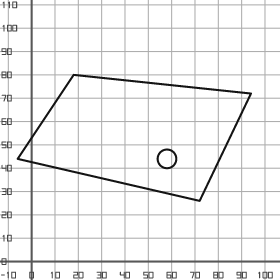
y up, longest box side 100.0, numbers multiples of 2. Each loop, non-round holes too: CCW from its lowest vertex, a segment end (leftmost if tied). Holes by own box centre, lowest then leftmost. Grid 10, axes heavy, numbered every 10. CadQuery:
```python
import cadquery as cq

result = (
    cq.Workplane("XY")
    .moveTo(72.0, 26.0)
    .lineTo(94.0, 72.0)
    .lineTo(18.0, 80.0)
    .lineTo(-6.0, 44.0)
    .close()
    .moveTo(58.0, 44.0)
    .circle(4.0)
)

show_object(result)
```